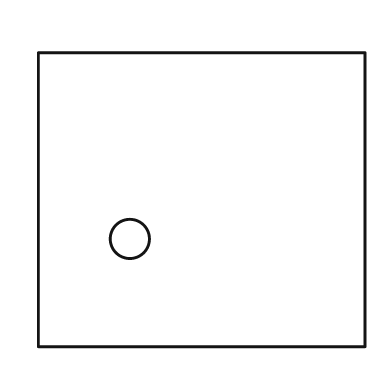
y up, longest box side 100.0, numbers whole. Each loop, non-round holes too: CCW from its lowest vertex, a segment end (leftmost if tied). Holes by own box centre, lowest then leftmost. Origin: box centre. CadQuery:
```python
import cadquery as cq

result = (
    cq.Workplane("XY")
    .moveTo(-50.0, -45.0)
    .lineTo(50.0, -45.0)
    .lineTo(50.0, 45.0)
    .lineTo(-50.0, 45.0)
    .close()
    .moveTo(-22.0, -12.0)
    .circle(6.0)
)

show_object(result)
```